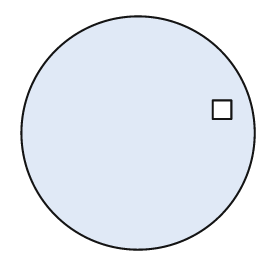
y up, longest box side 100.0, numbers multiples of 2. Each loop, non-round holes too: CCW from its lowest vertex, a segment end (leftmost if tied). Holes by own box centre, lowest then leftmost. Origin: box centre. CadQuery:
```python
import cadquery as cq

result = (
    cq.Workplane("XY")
    .moveTo(0.0, 0.0)
    .circle(50.0)
    .moveTo(32.0, 6.0)
    .lineTo(40.0, 6.0)
    .lineTo(40.0, 14.0)
    .lineTo(32.0, 14.0)
    .close()
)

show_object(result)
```